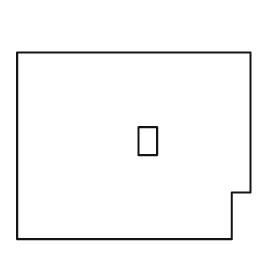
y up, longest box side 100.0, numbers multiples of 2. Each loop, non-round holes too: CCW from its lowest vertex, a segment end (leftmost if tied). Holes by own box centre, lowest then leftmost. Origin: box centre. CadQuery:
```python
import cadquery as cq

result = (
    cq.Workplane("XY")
    .moveTo(-50.0, -40.0)
    .lineTo(42.0, -40.0)
    .lineTo(42.0, -20.0)
    .lineTo(50.0, -20.0)
    .lineTo(50.0, 40.0)
    .lineTo(-50.0, 40.0)
    .close()
    .moveTo(2.0, -4.0)
    .lineTo(10.0, -4.0)
    .lineTo(10.0, 8.0)
    .lineTo(2.0, 8.0)
    .close()
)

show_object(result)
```